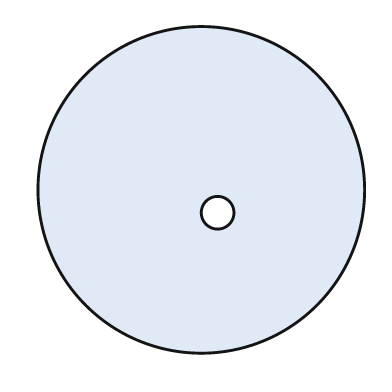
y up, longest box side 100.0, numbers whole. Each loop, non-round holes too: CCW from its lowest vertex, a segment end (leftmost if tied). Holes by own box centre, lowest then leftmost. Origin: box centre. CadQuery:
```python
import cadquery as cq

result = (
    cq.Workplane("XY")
    .moveTo(0.0, 0.0)
    .circle(50.0)
    .moveTo(5.0, -7.0)
    .circle(5.0)
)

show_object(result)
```